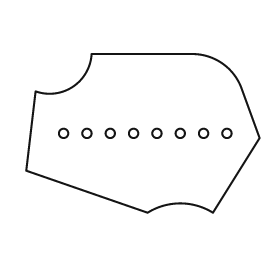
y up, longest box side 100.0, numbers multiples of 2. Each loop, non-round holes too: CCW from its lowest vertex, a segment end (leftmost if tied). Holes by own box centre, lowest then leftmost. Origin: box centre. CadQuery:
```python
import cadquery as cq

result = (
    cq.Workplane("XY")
    .moveTo(2.0, -34.0)
    .threePointArc((16.0, -30.0), (30.0, -34.0))
    .lineTo(50.0, -2.0)
    .lineTo(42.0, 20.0)
    .threePointArc((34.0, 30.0), (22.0, 34.0))
    .lineTo(-22.0, 34.0)
    .threePointArc((-30.0, 20.0), (-46.0, 18.0))
    .lineTo(-50.0, -16.0)
    .close()
    .moveTo(-34.0, 0.0)
    .circle(2.0)
    .moveTo(-24.0, 0.0)
    .circle(2.0)
    .moveTo(-14.0, 0.0)
    .circle(2.0)
    .moveTo(-4.0, 0.0)
    .circle(2.0)
    .moveTo(6.0, 0.0)
    .circle(2.0)
    .moveTo(16.0, 0.0)
    .circle(2.0)
    .moveTo(26.0, 0.0)
    .circle(2.0)
    .moveTo(36.0, 0.0)
    .circle(2.0)
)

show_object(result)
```